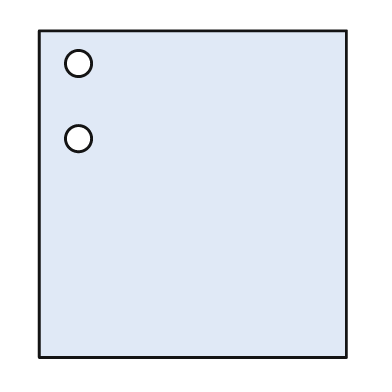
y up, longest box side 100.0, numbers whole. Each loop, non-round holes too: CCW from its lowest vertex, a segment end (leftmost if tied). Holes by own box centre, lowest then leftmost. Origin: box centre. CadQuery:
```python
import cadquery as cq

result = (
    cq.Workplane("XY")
    .moveTo(-47.0, -50.0)
    .lineTo(47.0, -50.0)
    .lineTo(47.0, 50.0)
    .lineTo(-47.0, 50.0)
    .close()
    .moveTo(-35.0, 17.0)
    .circle(4.0)
    .moveTo(-35.0, 40.0)
    .circle(4.0)
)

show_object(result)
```